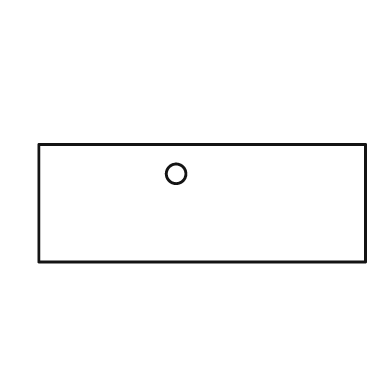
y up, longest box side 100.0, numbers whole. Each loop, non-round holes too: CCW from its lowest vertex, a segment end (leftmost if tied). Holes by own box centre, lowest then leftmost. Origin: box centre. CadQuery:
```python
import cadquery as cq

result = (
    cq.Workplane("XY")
    .moveTo(-50.0, -18.0)
    .lineTo(50.0, -18.0)
    .lineTo(50.0, 18.0)
    .lineTo(-50.0, 18.0)
    .close()
    .moveTo(-8.0, 9.0)
    .circle(3.0)
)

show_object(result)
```